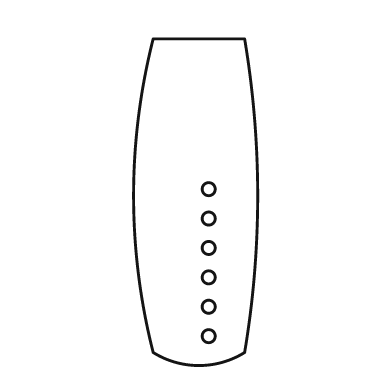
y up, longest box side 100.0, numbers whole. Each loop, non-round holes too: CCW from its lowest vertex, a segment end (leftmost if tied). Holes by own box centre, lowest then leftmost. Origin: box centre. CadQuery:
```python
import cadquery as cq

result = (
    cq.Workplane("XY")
    .moveTo(-13.0, -46.0)
    .threePointArc((1.0, -50.0), (15.0, -46.0))
    .threePointArc((19.0, 2.0), (15.0, 50.0))
    .lineTo(-13.0, 50.0)
    .threePointArc((-19.0, 2.0), (-13.0, -46.0))
    .close()
    .moveTo(4.0, -41.0)
    .circle(2.0)
    .moveTo(4.0, -32.0)
    .circle(2.0)
    .moveTo(4.0, -23.0)
    .circle(2.0)
    .moveTo(4.0, -14.0)
    .circle(2.0)
    .moveTo(4.0, -5.0)
    .circle(2.0)
    .moveTo(4.0, 4.0)
    .circle(2.0)
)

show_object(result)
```